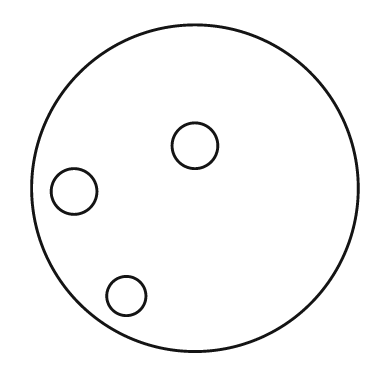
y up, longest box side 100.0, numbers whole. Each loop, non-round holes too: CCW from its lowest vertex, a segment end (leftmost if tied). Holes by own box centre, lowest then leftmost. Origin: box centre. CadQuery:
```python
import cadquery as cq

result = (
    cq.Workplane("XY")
    .moveTo(0.0, 0.0)
    .circle(50.0)
    .moveTo(-21.0, -33.0)
    .circle(6.0)
    .moveTo(-37.0, -1.0)
    .circle(7.0)
    .moveTo(0.0, 13.0)
    .circle(7.0)
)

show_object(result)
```